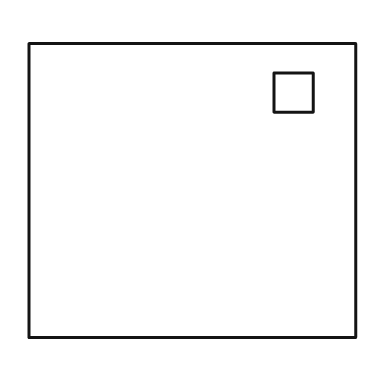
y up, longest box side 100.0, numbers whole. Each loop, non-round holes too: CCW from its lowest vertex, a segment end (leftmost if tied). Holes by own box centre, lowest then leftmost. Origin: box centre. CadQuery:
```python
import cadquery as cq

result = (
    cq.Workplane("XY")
    .moveTo(-50.0, -45.0)
    .lineTo(50.0, -45.0)
    .lineTo(50.0, 45.0)
    .lineTo(-50.0, 45.0)
    .close()
    .moveTo(25.0, 24.0)
    .lineTo(37.0, 24.0)
    .lineTo(37.0, 36.0)
    .lineTo(25.0, 36.0)
    .close()
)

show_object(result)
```